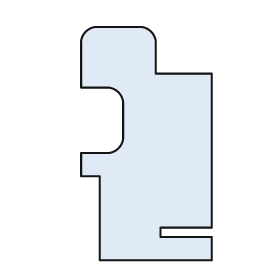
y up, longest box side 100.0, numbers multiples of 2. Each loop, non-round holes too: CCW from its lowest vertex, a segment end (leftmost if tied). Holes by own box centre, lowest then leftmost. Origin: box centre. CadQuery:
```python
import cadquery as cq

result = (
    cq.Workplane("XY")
    .moveTo(-20.0, -50.0)
    .lineTo(28.0, -50.0)
    .lineTo(28.0, -40.0)
    .lineTo(6.0, -40.0)
    .lineTo(6.0, -36.0)
    .lineTo(28.0, -36.0)
    .lineTo(28.0, 30.0)
    .lineTo(4.0, 30.0)
    .lineTo(4.0, 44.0)
    .threePointArc((2.0, 48.0), (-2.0, 50.0))
    .lineTo(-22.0, 50.0)
    .threePointArc((-26.0, 48.0), (-28.0, 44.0))
    .lineTo(-28.0, 24.0)
    .lineTo(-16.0, 24.0)
    .threePointArc((-12.0, 22.0), (-10.0, 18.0))
    .lineTo(-10.0, 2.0)
    .threePointArc((-12.0, -2.0), (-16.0, -4.0))
    .lineTo(-28.0, -4.0)
    .lineTo(-28.0, -14.0)
    .lineTo(-20.0, -14.0)
    .close()
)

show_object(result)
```